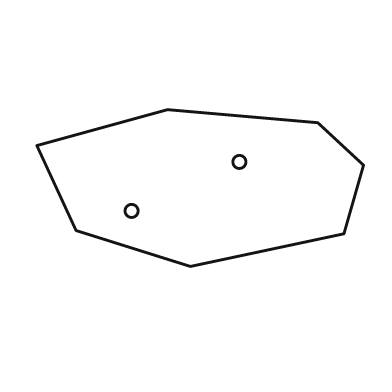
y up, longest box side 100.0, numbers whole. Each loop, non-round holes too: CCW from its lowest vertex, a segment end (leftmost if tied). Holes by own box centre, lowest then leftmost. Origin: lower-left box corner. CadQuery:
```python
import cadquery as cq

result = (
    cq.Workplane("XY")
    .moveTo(47.0, 0.0)
    .lineTo(94.0, 10.0)
    .lineTo(100.0, 31.0)
    .lineTo(86.0, 44.0)
    .lineTo(40.0, 48.0)
    .lineTo(0.0, 37.0)
    .lineTo(12.0, 11.0)
    .close()
    .moveTo(29.0, 17.0)
    .circle(2.0)
    .moveTo(62.0, 32.0)
    .circle(2.0)
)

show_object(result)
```